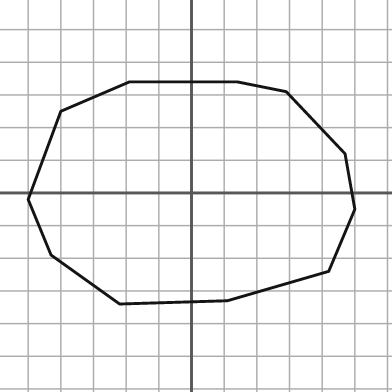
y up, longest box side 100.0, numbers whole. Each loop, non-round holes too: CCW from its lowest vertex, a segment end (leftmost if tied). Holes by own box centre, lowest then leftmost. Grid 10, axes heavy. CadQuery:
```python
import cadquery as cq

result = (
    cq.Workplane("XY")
    .moveTo(-22.0, -34.0)
    .lineTo(11.0, -33.0)
    .lineTo(42.0, -24.0)
    .lineTo(50.0, -5.0)
    .lineTo(47.0, 12.0)
    .lineTo(29.0, 31.0)
    .lineTo(14.0, 34.0)
    .lineTo(-19.0, 34.0)
    .lineTo(-40.0, 25.0)
    .lineTo(-50.0, -2.0)
    .lineTo(-43.0, -19.0)
    .close()
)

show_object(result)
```